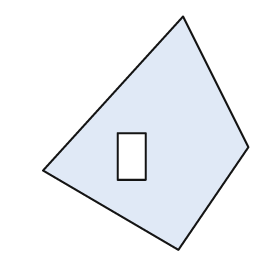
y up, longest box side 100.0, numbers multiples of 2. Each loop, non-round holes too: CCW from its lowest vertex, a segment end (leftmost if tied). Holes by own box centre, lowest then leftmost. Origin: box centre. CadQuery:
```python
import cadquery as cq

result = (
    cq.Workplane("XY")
    .moveTo(14.0, -50.0)
    .lineTo(44.0, -6.0)
    .lineTo(16.0, 50.0)
    .lineTo(-44.0, -16.0)
    .close()
    .moveTo(-12.0, -20.0)
    .lineTo(0.0, -20.0)
    .lineTo(0.0, 0.0)
    .lineTo(-12.0, 0.0)
    .close()
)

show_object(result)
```